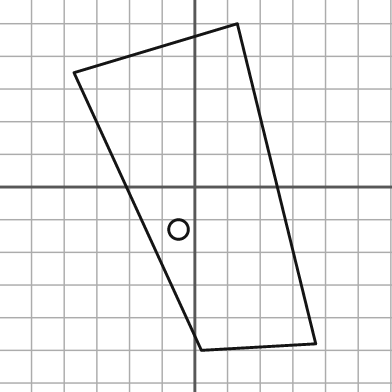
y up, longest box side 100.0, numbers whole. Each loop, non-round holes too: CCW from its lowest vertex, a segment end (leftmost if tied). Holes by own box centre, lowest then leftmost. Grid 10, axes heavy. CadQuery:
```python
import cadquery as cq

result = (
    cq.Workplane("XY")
    .moveTo(2.0, -50.0)
    .lineTo(37.0, -48.0)
    .lineTo(13.0, 50.0)
    .lineTo(-37.0, 35.0)
    .close()
    .moveTo(-5.0, -13.0)
    .circle(3.0)
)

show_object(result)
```